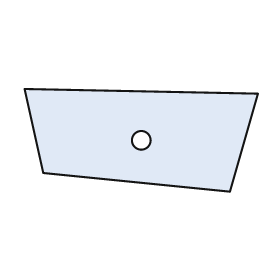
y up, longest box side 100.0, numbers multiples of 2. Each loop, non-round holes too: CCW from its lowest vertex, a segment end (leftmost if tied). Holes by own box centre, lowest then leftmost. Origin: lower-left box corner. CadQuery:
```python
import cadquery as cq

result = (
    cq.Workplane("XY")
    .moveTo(88.0, 0.0)
    .lineTo(100.0, 42.0)
    .lineTo(0.0, 44.0)
    .lineTo(8.0, 8.0)
    .close()
    .moveTo(50.0, 22.0)
    .circle(4.0)
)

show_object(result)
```